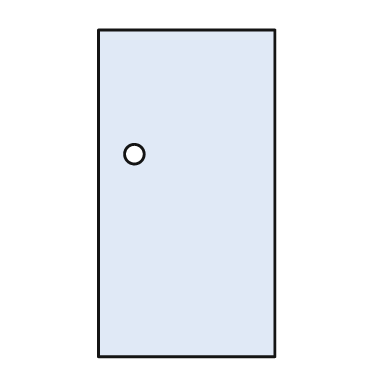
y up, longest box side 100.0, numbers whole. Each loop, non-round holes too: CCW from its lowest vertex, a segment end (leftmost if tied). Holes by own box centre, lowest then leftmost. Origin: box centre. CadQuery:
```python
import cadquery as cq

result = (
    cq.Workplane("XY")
    .moveTo(-27.0, -50.0)
    .lineTo(27.0, -50.0)
    .lineTo(27.0, 50.0)
    .lineTo(-27.0, 50.0)
    .close()
    .moveTo(-16.0, 12.0)
    .circle(3.0)
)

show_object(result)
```